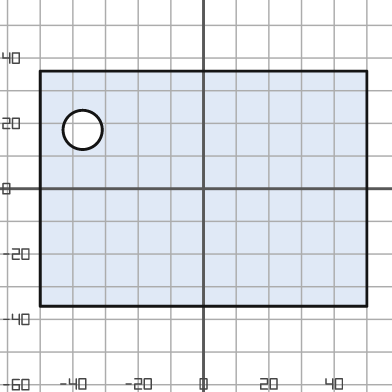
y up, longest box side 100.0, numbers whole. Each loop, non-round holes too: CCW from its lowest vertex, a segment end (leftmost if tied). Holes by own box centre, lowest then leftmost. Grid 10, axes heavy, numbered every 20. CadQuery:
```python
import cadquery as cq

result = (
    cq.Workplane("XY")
    .moveTo(-50.0, -36.0)
    .lineTo(50.0, -36.0)
    .lineTo(50.0, 36.0)
    .lineTo(-50.0, 36.0)
    .close()
    .moveTo(-37.0, 18.0)
    .circle(6.0)
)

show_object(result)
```